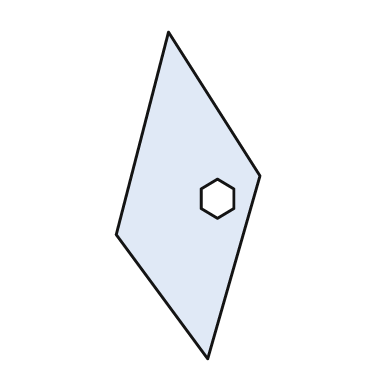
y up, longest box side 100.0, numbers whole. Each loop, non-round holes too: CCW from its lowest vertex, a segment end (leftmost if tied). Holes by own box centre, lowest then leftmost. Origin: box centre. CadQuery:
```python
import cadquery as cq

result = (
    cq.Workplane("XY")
    .moveTo(6.0, -50.0)
    .lineTo(22.0, 6.0)
    .lineTo(-6.0, 50.0)
    .lineTo(-22.0, -12.0)
    .close()
    .moveTo(9.0, -7.0)
    .lineTo(14.0, -4.0)
    .lineTo(14.0, 2.0)
    .lineTo(9.0, 5.0)
    .lineTo(4.0, 2.0)
    .lineTo(4.0, -4.0)
    .close()
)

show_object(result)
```